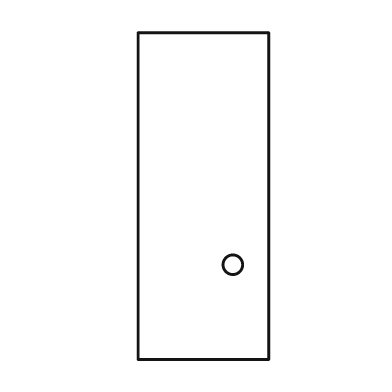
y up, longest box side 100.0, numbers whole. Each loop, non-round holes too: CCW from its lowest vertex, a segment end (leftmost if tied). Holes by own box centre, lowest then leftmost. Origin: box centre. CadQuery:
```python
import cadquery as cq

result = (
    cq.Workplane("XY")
    .moveTo(-20.0, -50.0)
    .lineTo(20.0, -50.0)
    .lineTo(20.0, 50.0)
    .lineTo(-20.0, 50.0)
    .close()
    .moveTo(9.0, -21.0)
    .circle(3.0)
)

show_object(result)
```